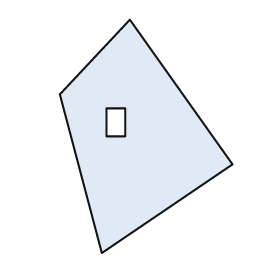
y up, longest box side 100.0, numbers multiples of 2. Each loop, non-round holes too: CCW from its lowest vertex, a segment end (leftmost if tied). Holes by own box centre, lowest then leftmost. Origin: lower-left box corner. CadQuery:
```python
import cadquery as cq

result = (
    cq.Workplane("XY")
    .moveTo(18.0, 0.0)
    .lineTo(74.0, 38.0)
    .lineTo(30.0, 100.0)
    .lineTo(0.0, 68.0)
    .close()
    .moveTo(20.0, 50.0)
    .lineTo(28.0, 50.0)
    .lineTo(28.0, 62.0)
    .lineTo(20.0, 62.0)
    .close()
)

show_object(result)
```